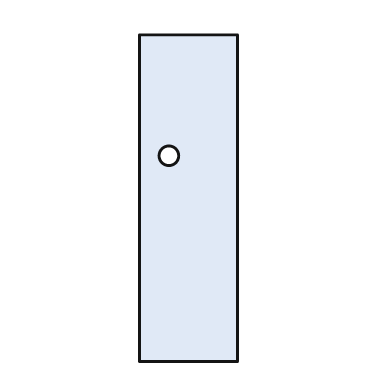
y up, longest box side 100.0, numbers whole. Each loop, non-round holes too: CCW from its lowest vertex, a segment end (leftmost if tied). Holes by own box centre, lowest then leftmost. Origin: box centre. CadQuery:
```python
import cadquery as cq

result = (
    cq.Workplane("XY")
    .moveTo(-15.0, -50.0)
    .lineTo(15.0, -50.0)
    .lineTo(15.0, 50.0)
    .lineTo(-15.0, 50.0)
    .close()
    .moveTo(-6.0, 13.0)
    .circle(3.0)
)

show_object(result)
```